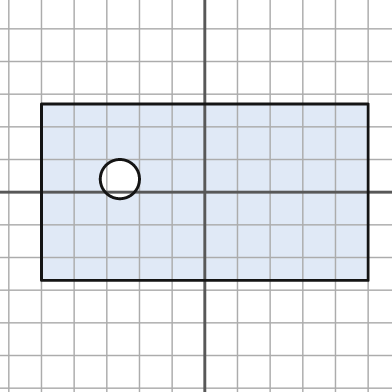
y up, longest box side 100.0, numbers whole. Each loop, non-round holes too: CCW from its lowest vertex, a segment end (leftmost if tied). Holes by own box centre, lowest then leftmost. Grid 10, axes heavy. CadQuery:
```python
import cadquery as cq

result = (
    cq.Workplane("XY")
    .moveTo(-50.0, -27.0)
    .lineTo(50.0, -27.0)
    .lineTo(50.0, 27.0)
    .lineTo(-50.0, 27.0)
    .close()
    .moveTo(-26.0, 4.0)
    .circle(6.0)
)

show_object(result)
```